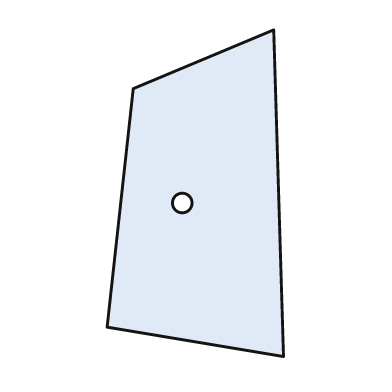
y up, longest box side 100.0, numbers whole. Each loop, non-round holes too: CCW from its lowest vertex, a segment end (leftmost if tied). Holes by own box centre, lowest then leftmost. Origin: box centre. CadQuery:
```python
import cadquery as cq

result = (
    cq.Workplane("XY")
    .moveTo(27.0, -50.0)
    .lineTo(24.0, 50.0)
    .lineTo(-19.0, 32.0)
    .lineTo(-27.0, -41.0)
    .close()
    .moveTo(-4.0, -3.0)
    .circle(3.0)
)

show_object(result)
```